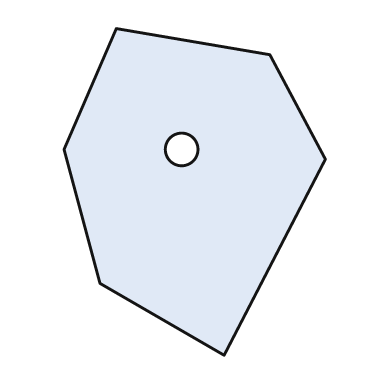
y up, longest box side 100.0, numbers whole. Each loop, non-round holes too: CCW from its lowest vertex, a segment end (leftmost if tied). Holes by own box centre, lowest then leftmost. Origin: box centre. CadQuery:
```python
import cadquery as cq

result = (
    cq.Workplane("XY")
    .moveTo(9.0, -50.0)
    .lineTo(40.0, 10.0)
    .lineTo(23.0, 42.0)
    .lineTo(-24.0, 50.0)
    .lineTo(-40.0, 13.0)
    .lineTo(-29.0, -28.0)
    .close()
    .moveTo(-4.0, 13.0)
    .circle(5.0)
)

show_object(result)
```